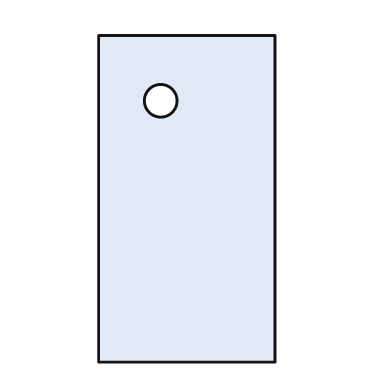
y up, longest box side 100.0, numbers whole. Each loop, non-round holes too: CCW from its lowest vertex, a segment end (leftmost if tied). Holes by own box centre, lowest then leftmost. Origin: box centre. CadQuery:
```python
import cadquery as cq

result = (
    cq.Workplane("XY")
    .moveTo(-27.0, -50.0)
    .lineTo(27.0, -50.0)
    .lineTo(27.0, 50.0)
    .lineTo(-27.0, 50.0)
    .close()
    .moveTo(-8.0, 30.0)
    .circle(5.0)
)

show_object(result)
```